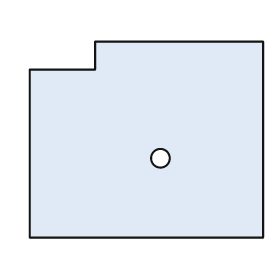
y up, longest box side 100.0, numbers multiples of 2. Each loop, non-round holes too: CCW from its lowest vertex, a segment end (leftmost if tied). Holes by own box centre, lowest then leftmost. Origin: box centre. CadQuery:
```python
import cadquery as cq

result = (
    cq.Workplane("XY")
    .moveTo(-50.0, -42.0)
    .lineTo(50.0, -42.0)
    .lineTo(50.0, 42.0)
    .lineTo(-22.0, 42.0)
    .lineTo(-22.0, 30.0)
    .lineTo(-50.0, 30.0)
    .close()
    .moveTo(6.0, -8.0)
    .circle(4.0)
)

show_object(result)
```